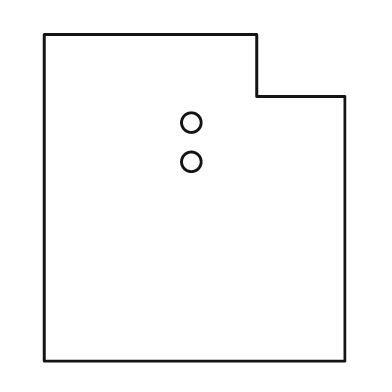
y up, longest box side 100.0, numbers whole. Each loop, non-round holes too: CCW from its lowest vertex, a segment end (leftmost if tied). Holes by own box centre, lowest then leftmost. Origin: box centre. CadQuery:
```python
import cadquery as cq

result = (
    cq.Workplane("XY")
    .moveTo(-46.0, -50.0)
    .lineTo(46.0, -50.0)
    .lineTo(46.0, 31.0)
    .lineTo(19.0, 31.0)
    .lineTo(19.0, 50.0)
    .lineTo(-46.0, 50.0)
    .close()
    .moveTo(-1.0, 11.0)
    .circle(3.0)
    .moveTo(-1.0, 23.0)
    .circle(3.0)
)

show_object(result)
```